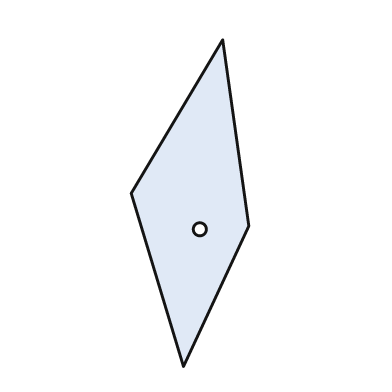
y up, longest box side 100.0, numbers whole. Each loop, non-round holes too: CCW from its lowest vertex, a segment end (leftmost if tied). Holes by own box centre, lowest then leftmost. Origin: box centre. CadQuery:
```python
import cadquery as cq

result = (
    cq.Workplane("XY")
    .moveTo(-2.0, -50.0)
    .lineTo(18.0, -7.0)
    .lineTo(10.0, 50.0)
    .lineTo(-18.0, 3.0)
    .close()
    .moveTo(3.0, -8.0)
    .circle(2.0)
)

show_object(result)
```